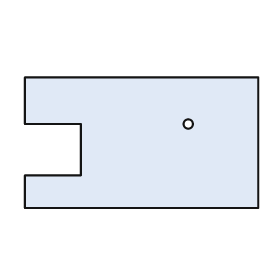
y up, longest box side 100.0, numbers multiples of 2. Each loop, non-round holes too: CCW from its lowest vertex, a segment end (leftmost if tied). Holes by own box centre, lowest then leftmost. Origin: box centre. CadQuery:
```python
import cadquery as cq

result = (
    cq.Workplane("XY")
    .moveTo(-50.0, -28.0)
    .lineTo(50.0, -28.0)
    .lineTo(50.0, 28.0)
    .lineTo(-50.0, 28.0)
    .lineTo(-50.0, 8.0)
    .lineTo(-26.0, 8.0)
    .lineTo(-26.0, -14.0)
    .lineTo(-50.0, -14.0)
    .close()
    .moveTo(20.0, 8.0)
    .circle(2.0)
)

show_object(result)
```